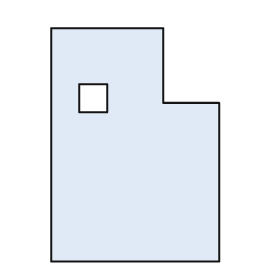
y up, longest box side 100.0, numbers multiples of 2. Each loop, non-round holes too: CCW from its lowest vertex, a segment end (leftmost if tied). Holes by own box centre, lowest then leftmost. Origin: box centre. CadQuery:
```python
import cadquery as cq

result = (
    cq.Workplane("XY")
    .moveTo(-36.0, -50.0)
    .lineTo(36.0, -50.0)
    .lineTo(36.0, 18.0)
    .lineTo(12.0, 18.0)
    .lineTo(12.0, 50.0)
    .lineTo(-36.0, 50.0)
    .close()
    .moveTo(-24.0, 14.0)
    .lineTo(-12.0, 14.0)
    .lineTo(-12.0, 26.0)
    .lineTo(-24.0, 26.0)
    .close()
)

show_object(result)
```